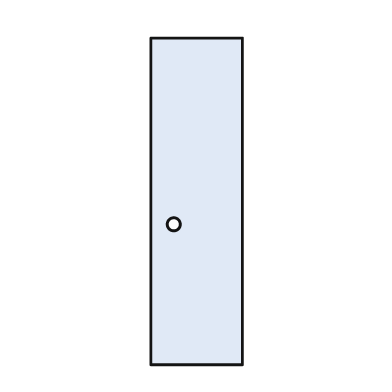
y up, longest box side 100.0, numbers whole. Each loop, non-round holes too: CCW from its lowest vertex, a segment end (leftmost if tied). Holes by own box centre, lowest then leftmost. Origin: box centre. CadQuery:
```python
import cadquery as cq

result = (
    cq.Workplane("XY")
    .moveTo(-14.0, -50.0)
    .lineTo(14.0, -50.0)
    .lineTo(14.0, 50.0)
    .lineTo(-14.0, 50.0)
    .close()
    .moveTo(-7.0, -7.0)
    .circle(2.0)
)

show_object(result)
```